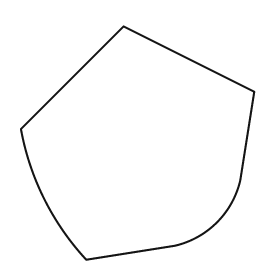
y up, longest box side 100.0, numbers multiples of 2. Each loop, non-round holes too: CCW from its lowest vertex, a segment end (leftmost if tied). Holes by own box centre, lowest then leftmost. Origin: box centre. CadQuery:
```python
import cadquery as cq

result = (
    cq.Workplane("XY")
    .moveTo(-22.0, -50.0)
    .lineTo(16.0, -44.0)
    .threePointArc((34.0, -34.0), (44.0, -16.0))
    .lineTo(50.0, 22.0)
    .lineTo(-6.0, 50.0)
    .lineTo(-50.0, 6.0)
    .threePointArc((-40.0, -24.0), (-22.0, -50.0))
    .close()
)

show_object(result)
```